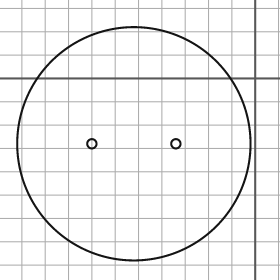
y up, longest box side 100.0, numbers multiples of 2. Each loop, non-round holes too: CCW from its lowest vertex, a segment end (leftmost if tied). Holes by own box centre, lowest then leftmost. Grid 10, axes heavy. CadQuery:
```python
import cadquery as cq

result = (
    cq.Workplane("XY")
    .moveTo(-52.0, -28.0)
    .circle(50.0)
    .moveTo(-70.0, -28.0)
    .circle(2.0)
    .moveTo(-34.0, -28.0)
    .circle(2.0)
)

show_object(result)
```